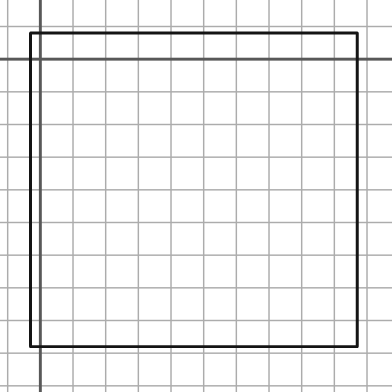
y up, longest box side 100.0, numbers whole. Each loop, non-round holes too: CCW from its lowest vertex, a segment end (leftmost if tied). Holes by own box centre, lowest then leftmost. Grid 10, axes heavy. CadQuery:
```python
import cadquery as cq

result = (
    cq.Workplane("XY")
    .moveTo(-3.0, -88.0)
    .lineTo(97.0, -88.0)
    .lineTo(97.0, 8.0)
    .lineTo(-3.0, 8.0)
    .close()
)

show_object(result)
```